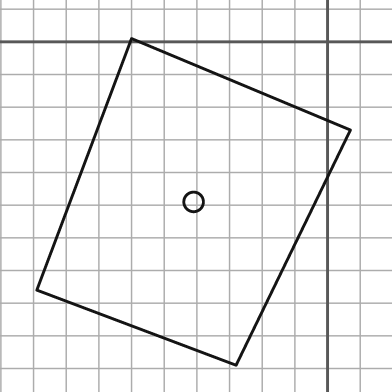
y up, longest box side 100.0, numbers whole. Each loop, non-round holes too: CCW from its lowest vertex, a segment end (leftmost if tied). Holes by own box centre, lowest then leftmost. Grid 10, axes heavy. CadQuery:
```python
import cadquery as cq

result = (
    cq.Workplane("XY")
    .moveTo(-28.0, -99.0)
    .lineTo(7.0, -27.0)
    .lineTo(-60.0, 1.0)
    .lineTo(-89.0, -76.0)
    .close()
    .moveTo(-41.0, -49.0)
    .circle(3.0)
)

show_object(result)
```